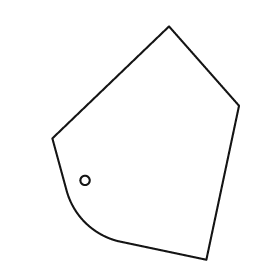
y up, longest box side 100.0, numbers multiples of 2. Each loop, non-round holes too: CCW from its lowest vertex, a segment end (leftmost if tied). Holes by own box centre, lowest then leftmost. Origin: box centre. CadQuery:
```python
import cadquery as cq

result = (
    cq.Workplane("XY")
    .moveTo(26.0, -50.0)
    .lineTo(40.0, 16.0)
    .lineTo(10.0, 50.0)
    .lineTo(-40.0, 2.0)
    .lineTo(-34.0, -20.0)
    .threePointArc((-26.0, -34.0), (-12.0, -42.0))
    .close()
    .moveTo(-26.0, -16.0)
    .circle(2.0)
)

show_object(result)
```